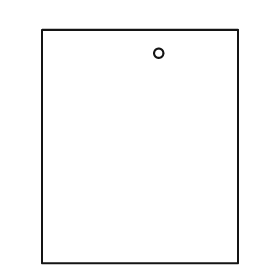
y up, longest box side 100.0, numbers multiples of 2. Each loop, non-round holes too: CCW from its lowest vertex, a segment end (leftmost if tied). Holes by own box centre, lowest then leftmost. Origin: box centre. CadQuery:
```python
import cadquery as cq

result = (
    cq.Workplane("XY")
    .moveTo(-42.0, -50.0)
    .lineTo(42.0, -50.0)
    .lineTo(42.0, 50.0)
    .lineTo(-42.0, 50.0)
    .close()
    .moveTo(8.0, 40.0)
    .circle(2.0)
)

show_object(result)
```